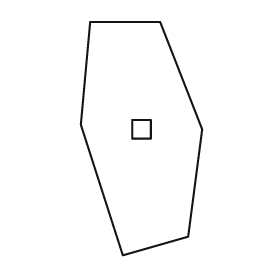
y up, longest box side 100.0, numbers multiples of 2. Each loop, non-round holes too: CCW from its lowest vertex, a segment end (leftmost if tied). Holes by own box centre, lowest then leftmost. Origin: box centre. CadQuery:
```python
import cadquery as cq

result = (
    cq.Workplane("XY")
    .moveTo(-8.0, -50.0)
    .lineTo(20.0, -42.0)
    .lineTo(26.0, 4.0)
    .lineTo(8.0, 50.0)
    .lineTo(-22.0, 50.0)
    .lineTo(-26.0, 6.0)
    .close()
    .moveTo(-4.0, 0.0)
    .lineTo(4.0, 0.0)
    .lineTo(4.0, 8.0)
    .lineTo(-4.0, 8.0)
    .close()
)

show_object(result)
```